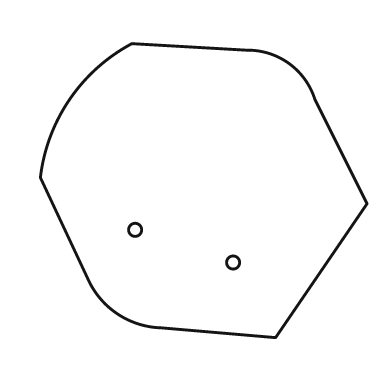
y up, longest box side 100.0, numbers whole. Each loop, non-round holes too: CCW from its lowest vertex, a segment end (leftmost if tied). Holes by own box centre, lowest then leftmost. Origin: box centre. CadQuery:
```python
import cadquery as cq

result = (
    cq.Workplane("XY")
    .moveTo(22.0, -45.0)
    .lineTo(50.0, -4.0)
    .lineTo(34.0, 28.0)
    .threePointArc((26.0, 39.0), (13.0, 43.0))
    .lineTo(-22.0, 45.0)
    .threePointArc((-41.0, 28.0), (-50.0, 4.0))
    .lineTo(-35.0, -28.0)
    .threePointArc((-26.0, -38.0), (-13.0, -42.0))
    .close()
    .moveTo(9.0, -22.0)
    .circle(2.0)
    .moveTo(-21.0, -12.0)
    .circle(2.0)
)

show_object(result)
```